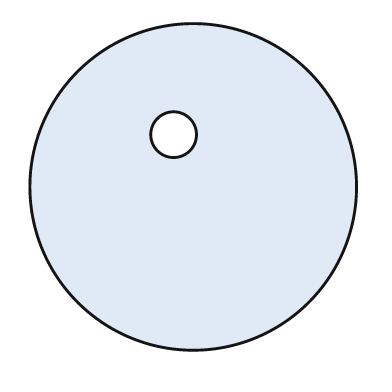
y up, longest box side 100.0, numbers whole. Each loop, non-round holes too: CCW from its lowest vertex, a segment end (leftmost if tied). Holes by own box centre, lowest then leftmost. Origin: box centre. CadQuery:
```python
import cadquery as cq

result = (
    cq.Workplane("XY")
    .moveTo(0.0, 0.0)
    .circle(50.0)
    .moveTo(-6.0, 16.0)
    .circle(7.0)
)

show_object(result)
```